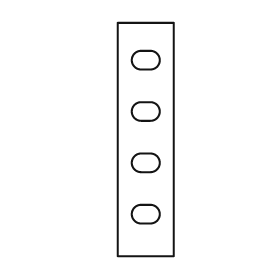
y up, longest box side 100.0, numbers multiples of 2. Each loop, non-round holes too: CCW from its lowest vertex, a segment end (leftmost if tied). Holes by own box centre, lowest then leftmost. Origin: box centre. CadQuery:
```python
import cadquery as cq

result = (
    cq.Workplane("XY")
    .moveTo(-12.0, -50.0)
    .lineTo(12.0, -50.0)
    .lineTo(12.0, 50.0)
    .lineTo(-12.0, 50.0)
    .close()
    .moveTo(-2.0, -36.0)
    .lineTo(2.0, -36.0)
    .threePointArc((6.0, -32.0), (2.0, -28.0))
    .lineTo(-2.0, -28.0)
    .threePointArc((-6.0, -32.0), (-2.0, -36.0))
    .close()
    .moveTo(-2.0, -14.0)
    .lineTo(2.0, -14.0)
    .threePointArc((6.0, -10.0), (2.0, -6.0))
    .lineTo(-2.0, -6.0)
    .threePointArc((-6.0, -10.0), (-2.0, -14.0))
    .close()
    .moveTo(-2.0, 8.0)
    .lineTo(2.0, 8.0)
    .threePointArc((6.0, 12.0), (2.0, 16.0))
    .lineTo(-2.0, 16.0)
    .threePointArc((-6.0, 12.0), (-2.0, 8.0))
    .close()
    .moveTo(-2.0, 30.0)
    .lineTo(2.0, 30.0)
    .threePointArc((6.0, 34.0), (2.0, 38.0))
    .lineTo(-2.0, 38.0)
    .threePointArc((-6.0, 34.0), (-2.0, 30.0))
    .close()
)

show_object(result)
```